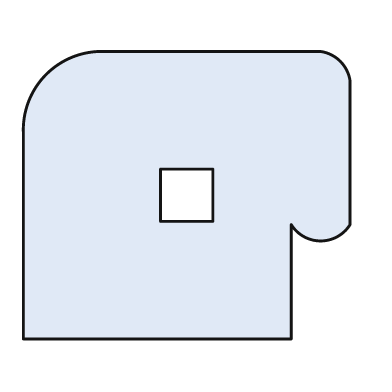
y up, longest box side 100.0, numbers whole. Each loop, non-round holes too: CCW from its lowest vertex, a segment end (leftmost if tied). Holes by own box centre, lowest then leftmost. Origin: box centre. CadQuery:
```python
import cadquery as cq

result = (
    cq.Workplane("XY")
    .moveTo(-50.0, -44.0)
    .lineTo(32.0, -44.0)
    .lineTo(32.0, -9.0)
    .threePointArc((41.0, -14.0), (50.0, -9.0))
    .lineTo(50.0, 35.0)
    .threePointArc((47.0, 41.0), (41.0, 44.0))
    .lineTo(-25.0, 44.0)
    .threePointArc((-43.0, 37.0), (-50.0, 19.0))
    .close()
    .moveTo(-8.0, -8.0)
    .lineTo(8.0, -8.0)
    .lineTo(8.0, 8.0)
    .lineTo(-8.0, 8.0)
    .close()
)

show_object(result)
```